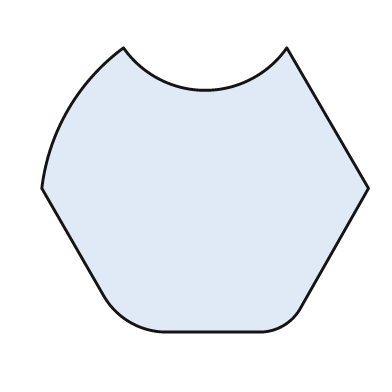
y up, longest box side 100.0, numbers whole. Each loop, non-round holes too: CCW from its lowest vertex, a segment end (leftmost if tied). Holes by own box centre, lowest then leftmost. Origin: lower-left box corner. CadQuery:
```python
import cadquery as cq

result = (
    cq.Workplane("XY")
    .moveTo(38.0, 0.0)
    .lineTo(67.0, 0.0)
    .threePointArc((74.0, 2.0), (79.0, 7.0))
    .lineTo(100.0, 44.0)
    .lineTo(75.0, 87.0)
    .threePointArc((50.0, 74.0), (25.0, 87.0))
    .threePointArc((8.0, 68.0), (0.0, 44.0))
    .lineTo(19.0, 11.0)
    .threePointArc((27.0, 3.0), (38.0, 0.0))
    .close()
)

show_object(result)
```